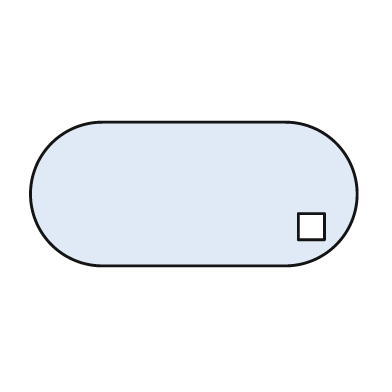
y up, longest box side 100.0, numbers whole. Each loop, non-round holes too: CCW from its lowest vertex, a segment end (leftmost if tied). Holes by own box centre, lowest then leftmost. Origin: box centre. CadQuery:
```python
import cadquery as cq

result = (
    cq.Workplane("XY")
    .moveTo(-28.0, -22.0)
    .lineTo(28.0, -22.0)
    .threePointArc((50.0, 0.0), (28.0, 22.0))
    .lineTo(-28.0, 22.0)
    .threePointArc((-50.0, 0.0), (-28.0, -22.0))
    .close()
    .moveTo(32.0, -14.0)
    .lineTo(40.0, -14.0)
    .lineTo(40.0, -6.0)
    .lineTo(32.0, -6.0)
    .close()
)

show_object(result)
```